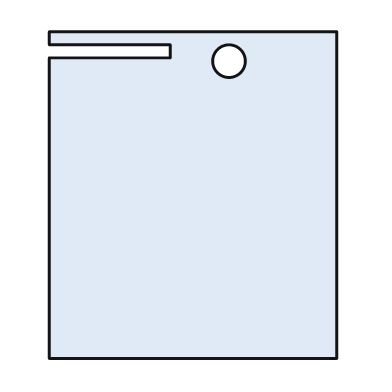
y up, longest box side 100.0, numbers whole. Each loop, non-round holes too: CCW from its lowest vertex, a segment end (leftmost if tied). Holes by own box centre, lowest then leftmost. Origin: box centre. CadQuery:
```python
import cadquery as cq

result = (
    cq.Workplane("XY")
    .moveTo(-44.0, -50.0)
    .lineTo(44.0, -50.0)
    .lineTo(44.0, 50.0)
    .lineTo(-44.0, 50.0)
    .lineTo(-44.0, 46.0)
    .lineTo(-7.0, 46.0)
    .lineTo(-7.0, 42.0)
    .lineTo(-44.0, 42.0)
    .close()
    .moveTo(11.0, 41.0)
    .circle(5.0)
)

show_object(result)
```